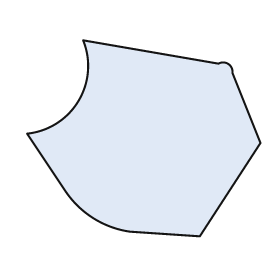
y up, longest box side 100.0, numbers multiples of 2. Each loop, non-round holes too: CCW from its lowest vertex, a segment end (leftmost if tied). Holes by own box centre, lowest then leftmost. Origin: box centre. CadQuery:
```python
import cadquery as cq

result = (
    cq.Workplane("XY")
    .moveTo(24.0, -42.0)
    .lineTo(50.0, -2.0)
    .lineTo(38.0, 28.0)
    .threePointArc((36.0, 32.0), (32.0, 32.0))
    .lineTo(-26.0, 42.0)
    .threePointArc((-28.0, 16.0), (-50.0, 2.0))
    .lineTo(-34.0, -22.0)
    .threePointArc((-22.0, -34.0), (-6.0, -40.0))
    .close()
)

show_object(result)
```